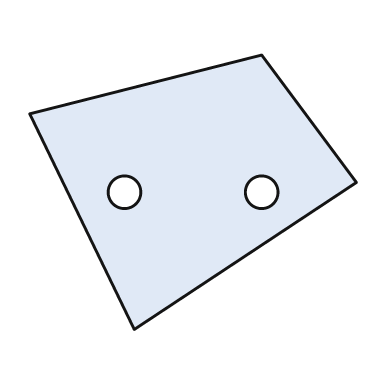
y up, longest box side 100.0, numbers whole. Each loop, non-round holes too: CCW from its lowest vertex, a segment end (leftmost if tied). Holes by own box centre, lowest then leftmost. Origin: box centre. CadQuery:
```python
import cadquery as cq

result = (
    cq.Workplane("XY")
    .moveTo(-18.0, -42.0)
    .lineTo(50.0, 3.0)
    .lineTo(21.0, 42.0)
    .lineTo(-50.0, 24.0)
    .close()
    .moveTo(-21.0, 0.0)
    .circle(5.0)
    .moveTo(21.0, 0.0)
    .circle(5.0)
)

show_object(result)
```